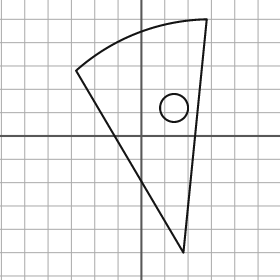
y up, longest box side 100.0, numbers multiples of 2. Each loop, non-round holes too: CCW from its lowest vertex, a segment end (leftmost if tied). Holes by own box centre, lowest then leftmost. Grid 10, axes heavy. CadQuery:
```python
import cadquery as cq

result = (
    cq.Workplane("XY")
    .moveTo(18.0, -50.0)
    .lineTo(28.0, 50.0)
    .threePointArc((-2.0, 44.0), (-28.0, 28.0))
    .close()
    .moveTo(14.0, 12.0)
    .circle(6.0)
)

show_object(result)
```